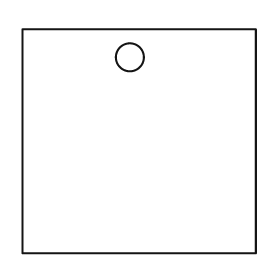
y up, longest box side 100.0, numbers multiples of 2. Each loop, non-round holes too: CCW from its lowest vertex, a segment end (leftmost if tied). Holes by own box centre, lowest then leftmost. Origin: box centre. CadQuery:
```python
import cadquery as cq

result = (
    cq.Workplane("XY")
    .moveTo(-50.0, -48.0)
    .lineTo(50.0, -48.0)
    .lineTo(50.0, 48.0)
    .lineTo(-50.0, 48.0)
    .close()
    .moveTo(-4.0, 36.0)
    .circle(6.0)
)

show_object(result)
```